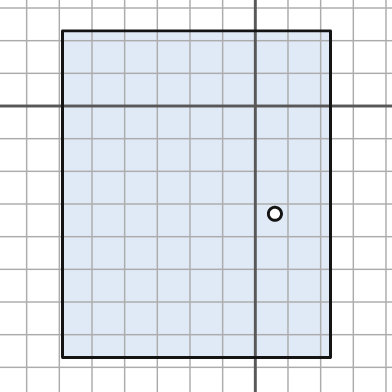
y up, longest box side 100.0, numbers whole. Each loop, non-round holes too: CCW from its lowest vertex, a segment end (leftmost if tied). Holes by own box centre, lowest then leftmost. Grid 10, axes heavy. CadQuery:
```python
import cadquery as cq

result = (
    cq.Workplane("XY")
    .moveTo(-59.0, -77.0)
    .lineTo(23.0, -77.0)
    .lineTo(23.0, 23.0)
    .lineTo(-59.0, 23.0)
    .close()
    .moveTo(6.0, -33.0)
    .circle(2.0)
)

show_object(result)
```